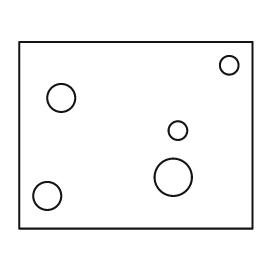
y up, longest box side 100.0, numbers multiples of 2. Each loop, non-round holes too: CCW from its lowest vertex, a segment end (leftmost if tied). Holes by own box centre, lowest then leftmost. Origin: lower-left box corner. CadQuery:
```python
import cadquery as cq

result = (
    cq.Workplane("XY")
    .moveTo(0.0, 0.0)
    .lineTo(100.0, 0.0)
    .lineTo(100.0, 80.0)
    .lineTo(0.0, 80.0)
    .close()
    .moveTo(12.0, 14.0)
    .circle(6.0)
    .moveTo(66.0, 22.0)
    .circle(8.0)
    .moveTo(68.0, 42.0)
    .circle(4.0)
    .moveTo(18.0, 56.0)
    .circle(6.0)
    .moveTo(90.0, 70.0)
    .circle(4.0)
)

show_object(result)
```